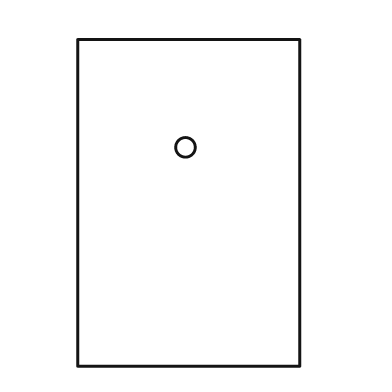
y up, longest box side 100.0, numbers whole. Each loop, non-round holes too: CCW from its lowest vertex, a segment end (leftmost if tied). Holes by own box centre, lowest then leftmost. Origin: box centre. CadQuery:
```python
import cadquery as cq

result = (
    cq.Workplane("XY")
    .moveTo(-34.0, -50.0)
    .lineTo(34.0, -50.0)
    .lineTo(34.0, 50.0)
    .lineTo(-34.0, 50.0)
    .close()
    .moveTo(-1.0, 17.0)
    .circle(3.0)
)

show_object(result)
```